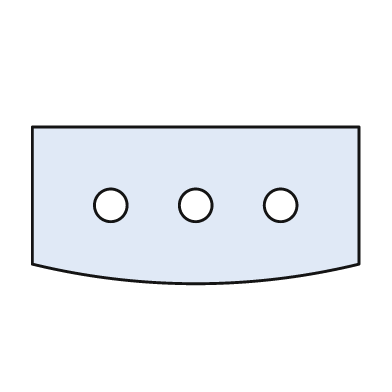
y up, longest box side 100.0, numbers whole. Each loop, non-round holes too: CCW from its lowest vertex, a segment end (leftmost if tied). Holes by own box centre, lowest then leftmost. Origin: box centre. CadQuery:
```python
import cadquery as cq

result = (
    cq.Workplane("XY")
    .moveTo(-50.0, -18.0)
    .threePointArc((0.0, -24.0), (50.0, -18.0))
    .lineTo(50.0, 24.0)
    .lineTo(-50.0, 24.0)
    .close()
    .moveTo(-26.0, 0.0)
    .circle(5.0)
    .moveTo(0.0, 0.0)
    .circle(5.0)
    .moveTo(26.0, 0.0)
    .circle(5.0)
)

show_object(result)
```